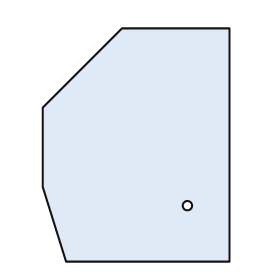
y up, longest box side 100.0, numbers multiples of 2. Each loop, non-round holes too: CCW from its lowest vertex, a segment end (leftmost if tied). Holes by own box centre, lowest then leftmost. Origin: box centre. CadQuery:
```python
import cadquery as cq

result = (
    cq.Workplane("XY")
    .moveTo(-30.0, -50.0)
    .lineTo(40.0, -50.0)
    .lineTo(40.0, 50.0)
    .lineTo(-6.0, 50.0)
    .lineTo(-40.0, 16.0)
    .lineTo(-40.0, -18.0)
    .close()
    .moveTo(22.0, -26.0)
    .circle(2.0)
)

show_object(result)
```